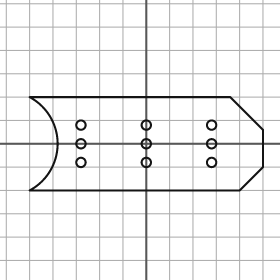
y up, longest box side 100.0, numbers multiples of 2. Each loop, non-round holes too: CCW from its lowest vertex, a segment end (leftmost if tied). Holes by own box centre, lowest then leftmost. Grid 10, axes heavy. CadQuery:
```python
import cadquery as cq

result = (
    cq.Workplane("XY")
    .moveTo(-50.0, -20.0)
    .lineTo(40.0, -20.0)
    .lineTo(50.0, -10.0)
    .lineTo(50.0, 6.0)
    .lineTo(36.0, 20.0)
    .lineTo(-50.0, 20.0)
    .threePointArc((-38.0, 0.0), (-50.0, -20.0))
    .close()
    .moveTo(-28.0, -8.0)
    .circle(2.0)
    .moveTo(0.0, -8.0)
    .circle(2.0)
    .moveTo(28.0, -8.0)
    .circle(2.0)
    .moveTo(-28.0, 0.0)
    .circle(2.0)
    .moveTo(0.0, 0.0)
    .circle(2.0)
    .moveTo(28.0, 0.0)
    .circle(2.0)
    .moveTo(-28.0, 8.0)
    .circle(2.0)
    .moveTo(0.0, 8.0)
    .circle(2.0)
    .moveTo(28.0, 8.0)
    .circle(2.0)
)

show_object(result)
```